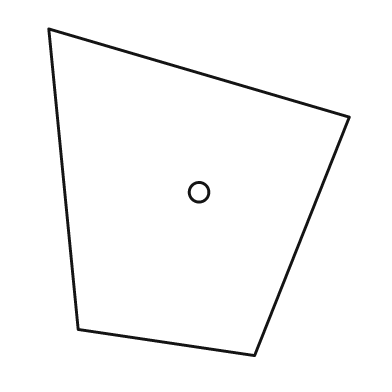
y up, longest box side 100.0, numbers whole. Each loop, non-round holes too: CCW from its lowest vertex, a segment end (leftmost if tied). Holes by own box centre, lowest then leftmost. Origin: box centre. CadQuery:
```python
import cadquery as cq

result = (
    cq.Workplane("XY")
    .moveTo(17.0, -50.0)
    .lineTo(46.0, 23.0)
    .lineTo(-46.0, 50.0)
    .lineTo(-37.0, -42.0)
    .close()
    .moveTo(0.0, 0.0)
    .circle(3.0)
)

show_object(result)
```